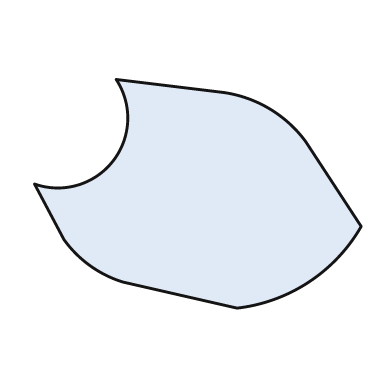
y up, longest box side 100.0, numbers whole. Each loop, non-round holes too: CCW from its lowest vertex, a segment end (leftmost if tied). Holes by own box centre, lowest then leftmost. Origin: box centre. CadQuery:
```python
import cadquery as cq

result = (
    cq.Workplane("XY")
    .moveTo(12.0, -35.0)
    .threePointArc((34.0, -27.0), (50.0, -10.0))
    .lineTo(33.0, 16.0)
    .threePointArc((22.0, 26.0), (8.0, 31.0))
    .lineTo(-25.0, 35.0)
    .threePointArc((-26.0, 10.0), (-50.0, 3.0))
    .lineTo(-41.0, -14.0)
    .threePointArc((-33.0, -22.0), (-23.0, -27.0))
    .close()
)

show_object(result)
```